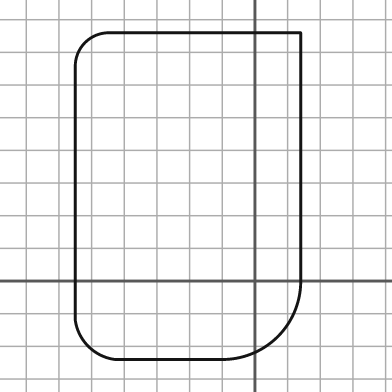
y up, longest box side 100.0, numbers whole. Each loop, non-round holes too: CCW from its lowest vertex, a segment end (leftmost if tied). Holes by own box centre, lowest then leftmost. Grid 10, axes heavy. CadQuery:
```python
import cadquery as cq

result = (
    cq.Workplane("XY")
    .moveTo(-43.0, -24.0)
    .lineTo(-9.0, -24.0)
    .threePointArc((7.0, -17.0), (14.0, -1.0))
    .lineTo(14.0, 76.0)
    .lineTo(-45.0, 76.0)
    .threePointArc((-52.0, 73.0), (-55.0, 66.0))
    .lineTo(-55.0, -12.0)
    .threePointArc((-51.0, -20.0), (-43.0, -24.0))
    .close()
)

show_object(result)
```